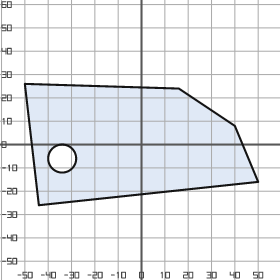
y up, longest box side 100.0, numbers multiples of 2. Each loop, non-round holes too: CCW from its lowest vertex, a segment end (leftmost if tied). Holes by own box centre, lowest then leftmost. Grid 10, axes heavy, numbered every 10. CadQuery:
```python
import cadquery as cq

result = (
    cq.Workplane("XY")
    .moveTo(-44.0, -26.0)
    .lineTo(50.0, -16.0)
    .lineTo(40.0, 8.0)
    .lineTo(16.0, 24.0)
    .lineTo(-50.0, 26.0)
    .close()
    .moveTo(-34.0, -6.0)
    .circle(6.0)
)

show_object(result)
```